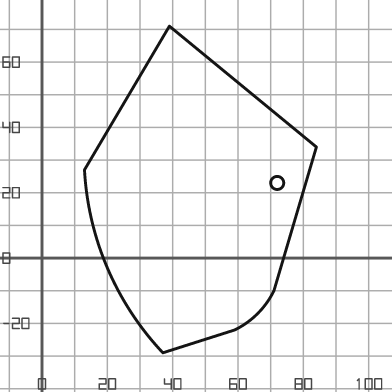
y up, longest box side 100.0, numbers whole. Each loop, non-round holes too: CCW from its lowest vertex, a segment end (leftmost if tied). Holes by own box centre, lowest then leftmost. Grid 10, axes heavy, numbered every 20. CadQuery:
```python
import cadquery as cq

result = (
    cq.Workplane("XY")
    .moveTo(37.0, -29.0)
    .lineTo(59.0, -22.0)
    .threePointArc((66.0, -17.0), (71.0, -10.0))
    .lineTo(84.0, 34.0)
    .lineTo(39.0, 71.0)
    .lineTo(13.0, 27.0)
    .threePointArc((20.0, -3.0), (37.0, -29.0))
    .close()
    .moveTo(72.0, 23.0)
    .circle(2.0)
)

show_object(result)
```